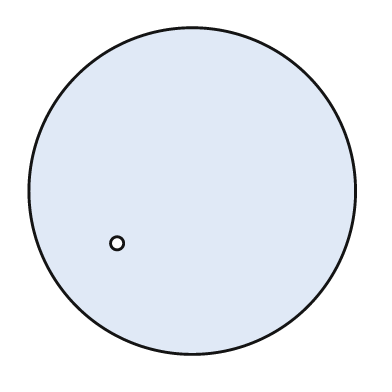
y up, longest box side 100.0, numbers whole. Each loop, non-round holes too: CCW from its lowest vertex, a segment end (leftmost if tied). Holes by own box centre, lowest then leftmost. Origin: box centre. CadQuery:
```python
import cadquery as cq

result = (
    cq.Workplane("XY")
    .moveTo(0.0, 0.0)
    .circle(50.0)
    .moveTo(-23.0, -16.0)
    .circle(2.0)
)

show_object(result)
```